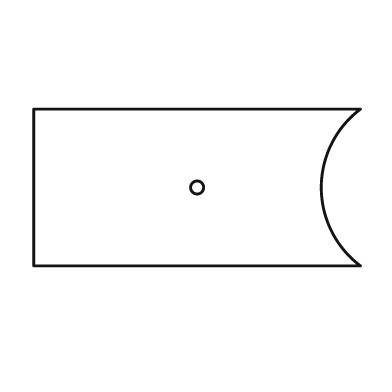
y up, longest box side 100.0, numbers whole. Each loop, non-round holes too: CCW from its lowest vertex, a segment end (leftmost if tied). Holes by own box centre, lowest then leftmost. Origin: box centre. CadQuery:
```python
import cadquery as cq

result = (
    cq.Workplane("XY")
    .moveTo(-50.0, -24.0)
    .lineTo(50.0, -24.0)
    .threePointArc((38.0, 0.0), (50.0, 24.0))
    .lineTo(-50.0, 24.0)
    .close()
    .moveTo(0.0, 0.0)
    .circle(2.0)
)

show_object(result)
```